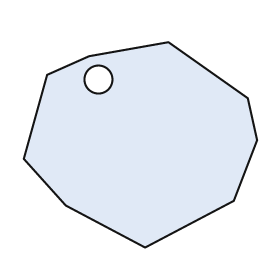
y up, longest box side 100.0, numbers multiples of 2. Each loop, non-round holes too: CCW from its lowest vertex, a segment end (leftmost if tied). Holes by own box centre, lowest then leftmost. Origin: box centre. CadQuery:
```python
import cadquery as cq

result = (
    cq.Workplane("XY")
    .moveTo(2.0, -44.0)
    .lineTo(40.0, -24.0)
    .lineTo(50.0, 2.0)
    .lineTo(46.0, 20.0)
    .lineTo(12.0, 44.0)
    .lineTo(-22.0, 38.0)
    .lineTo(-40.0, 30.0)
    .lineTo(-50.0, -6.0)
    .lineTo(-32.0, -26.0)
    .close()
    .moveTo(-18.0, 28.0)
    .circle(6.0)
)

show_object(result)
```